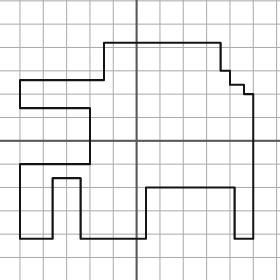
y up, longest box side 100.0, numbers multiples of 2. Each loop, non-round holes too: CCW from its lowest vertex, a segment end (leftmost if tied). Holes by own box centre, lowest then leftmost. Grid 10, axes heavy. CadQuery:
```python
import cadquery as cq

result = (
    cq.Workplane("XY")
    .moveTo(-50.0, -42.0)
    .lineTo(-36.0, -42.0)
    .lineTo(-36.0, -16.0)
    .lineTo(-24.0, -16.0)
    .lineTo(-24.0, -42.0)
    .lineTo(4.0, -42.0)
    .lineTo(4.0, -20.0)
    .lineTo(42.0, -20.0)
    .lineTo(42.0, -42.0)
    .lineTo(50.0, -42.0)
    .lineTo(50.0, 20.0)
    .lineTo(46.0, 20.0)
    .lineTo(46.0, 24.0)
    .lineTo(40.0, 24.0)
    .lineTo(40.0, 30.0)
    .lineTo(36.0, 30.0)
    .lineTo(36.0, 42.0)
    .lineTo(-14.0, 42.0)
    .lineTo(-14.0, 26.0)
    .lineTo(-50.0, 26.0)
    .lineTo(-50.0, 14.0)
    .lineTo(-20.0, 14.0)
    .lineTo(-20.0, -10.0)
    .lineTo(-50.0, -10.0)
    .close()
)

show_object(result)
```